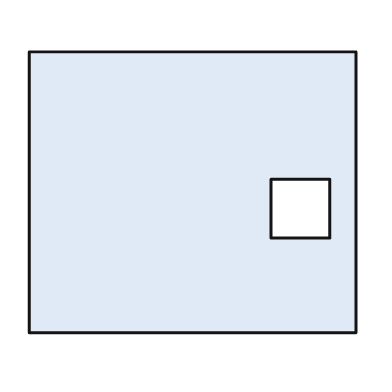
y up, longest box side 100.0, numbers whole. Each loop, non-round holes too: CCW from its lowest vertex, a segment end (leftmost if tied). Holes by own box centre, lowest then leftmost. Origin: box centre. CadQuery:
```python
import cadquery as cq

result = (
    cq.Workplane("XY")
    .moveTo(-50.0, -43.0)
    .lineTo(50.0, -43.0)
    .lineTo(50.0, 43.0)
    .lineTo(-50.0, 43.0)
    .close()
    .moveTo(24.0, -14.0)
    .lineTo(42.0, -14.0)
    .lineTo(42.0, 4.0)
    .lineTo(24.0, 4.0)
    .close()
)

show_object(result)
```